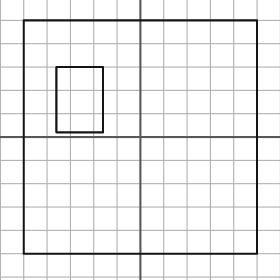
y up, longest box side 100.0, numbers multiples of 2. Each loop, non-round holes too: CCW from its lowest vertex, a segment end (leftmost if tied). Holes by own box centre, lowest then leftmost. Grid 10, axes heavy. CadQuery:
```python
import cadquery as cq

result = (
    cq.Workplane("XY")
    .moveTo(-50.0, -50.0)
    .lineTo(50.0, -50.0)
    .lineTo(50.0, 50.0)
    .lineTo(-50.0, 50.0)
    .close()
    .moveTo(-36.0, 2.0)
    .lineTo(-16.0, 2.0)
    .lineTo(-16.0, 30.0)
    .lineTo(-36.0, 30.0)
    .close()
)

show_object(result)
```